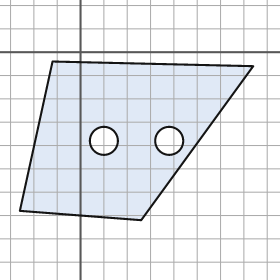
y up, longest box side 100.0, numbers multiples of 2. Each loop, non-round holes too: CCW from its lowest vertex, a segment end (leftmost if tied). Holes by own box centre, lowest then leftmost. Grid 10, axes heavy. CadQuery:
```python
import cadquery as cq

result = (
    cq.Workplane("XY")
    .moveTo(26.0, -72.0)
    .lineTo(74.0, -6.0)
    .lineTo(-12.0, -4.0)
    .lineTo(-26.0, -68.0)
    .close()
    .moveTo(10.0, -38.0)
    .circle(6.0)
    .moveTo(38.0, -38.0)
    .circle(6.0)
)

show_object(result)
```